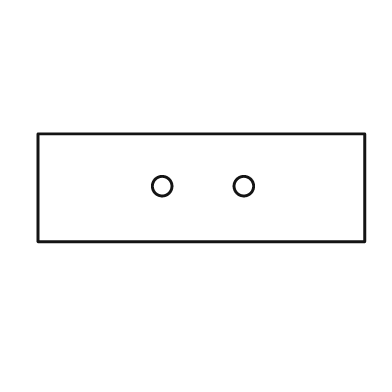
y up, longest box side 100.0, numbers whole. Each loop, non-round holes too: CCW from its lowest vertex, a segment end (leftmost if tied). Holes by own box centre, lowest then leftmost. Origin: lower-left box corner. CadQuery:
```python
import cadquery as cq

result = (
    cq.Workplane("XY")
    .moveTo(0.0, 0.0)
    .lineTo(100.0, 0.0)
    .lineTo(100.0, 33.0)
    .lineTo(0.0, 33.0)
    .close()
    .moveTo(38.0, 17.0)
    .circle(3.0)
    .moveTo(63.0, 17.0)
    .circle(3.0)
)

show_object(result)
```